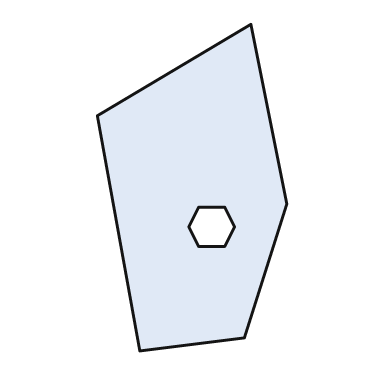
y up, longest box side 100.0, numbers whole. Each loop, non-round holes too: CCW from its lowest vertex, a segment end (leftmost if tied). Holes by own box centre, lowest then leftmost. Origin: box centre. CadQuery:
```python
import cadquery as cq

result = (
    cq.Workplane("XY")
    .moveTo(-16.0, -50.0)
    .lineTo(16.0, -46.0)
    .lineTo(29.0, -5.0)
    .lineTo(18.0, 50.0)
    .lineTo(-29.0, 22.0)
    .close()
    .moveTo(2.0, -18.0)
    .lineTo(10.0, -18.0)
    .lineTo(13.0, -12.0)
    .lineTo(10.0, -6.0)
    .lineTo(2.0, -6.0)
    .lineTo(-1.0, -12.0)
    .close()
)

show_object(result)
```